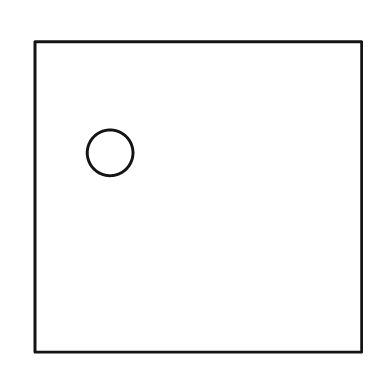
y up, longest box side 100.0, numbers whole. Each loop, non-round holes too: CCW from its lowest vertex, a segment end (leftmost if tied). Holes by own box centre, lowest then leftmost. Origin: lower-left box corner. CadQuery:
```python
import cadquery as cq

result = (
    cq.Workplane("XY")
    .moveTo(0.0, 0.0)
    .lineTo(100.0, 0.0)
    .lineTo(100.0, 95.0)
    .lineTo(0.0, 95.0)
    .close()
    .moveTo(23.0, 61.0)
    .circle(7.0)
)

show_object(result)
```